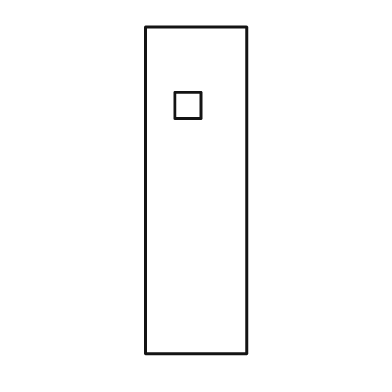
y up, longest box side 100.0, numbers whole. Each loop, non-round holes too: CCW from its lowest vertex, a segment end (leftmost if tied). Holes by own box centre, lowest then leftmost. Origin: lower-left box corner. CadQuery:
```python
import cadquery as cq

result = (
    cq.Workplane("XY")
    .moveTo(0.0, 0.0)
    .lineTo(31.0, 0.0)
    .lineTo(31.0, 100.0)
    .lineTo(0.0, 100.0)
    .close()
    .moveTo(9.0, 72.0)
    .lineTo(17.0, 72.0)
    .lineTo(17.0, 80.0)
    .lineTo(9.0, 80.0)
    .close()
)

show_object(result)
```